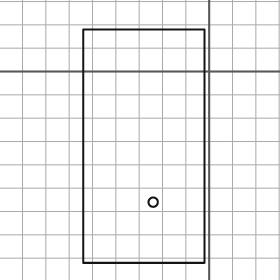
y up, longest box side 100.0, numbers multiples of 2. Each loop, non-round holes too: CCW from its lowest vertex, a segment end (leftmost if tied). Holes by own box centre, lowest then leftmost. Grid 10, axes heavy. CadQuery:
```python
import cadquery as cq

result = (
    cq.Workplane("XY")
    .moveTo(-54.0, -82.0)
    .lineTo(-2.0, -82.0)
    .lineTo(-2.0, 18.0)
    .lineTo(-54.0, 18.0)
    .close()
    .moveTo(-24.0, -56.0)
    .circle(2.0)
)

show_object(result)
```